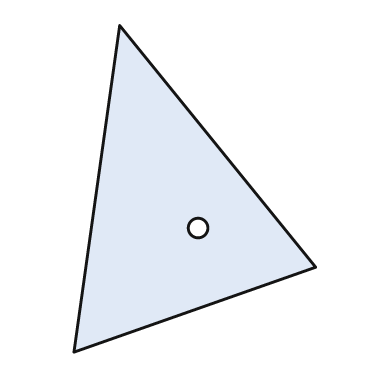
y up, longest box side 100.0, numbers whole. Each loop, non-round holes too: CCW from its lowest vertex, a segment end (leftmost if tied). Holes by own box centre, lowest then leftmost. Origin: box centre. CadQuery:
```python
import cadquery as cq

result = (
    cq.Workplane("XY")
    .moveTo(-37.0, -50.0)
    .lineTo(37.0, -24.0)
    .lineTo(-23.0, 50.0)
    .close()
    .moveTo(1.0, -12.0)
    .circle(3.0)
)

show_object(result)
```